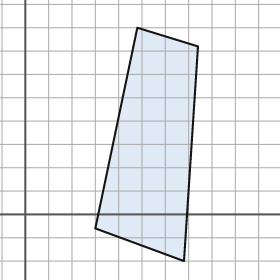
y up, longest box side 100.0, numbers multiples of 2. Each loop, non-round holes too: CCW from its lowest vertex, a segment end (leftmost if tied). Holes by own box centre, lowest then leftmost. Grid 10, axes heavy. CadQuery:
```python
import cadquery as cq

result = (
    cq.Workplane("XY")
    .moveTo(68.0, -20.0)
    .lineTo(74.0, 72.0)
    .lineTo(48.0, 80.0)
    .lineTo(30.0, -6.0)
    .close()
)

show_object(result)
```